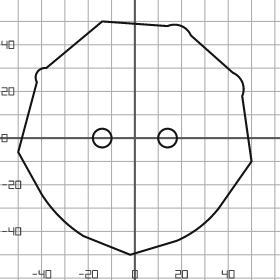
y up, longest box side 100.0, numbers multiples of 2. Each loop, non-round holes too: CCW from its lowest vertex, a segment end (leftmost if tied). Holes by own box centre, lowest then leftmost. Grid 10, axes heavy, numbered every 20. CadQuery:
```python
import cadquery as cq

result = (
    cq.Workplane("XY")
    .moveTo(-2.0, -50.0)
    .lineTo(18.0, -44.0)
    .threePointArc((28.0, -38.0), (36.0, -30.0))
    .lineTo(50.0, -10.0)
    .lineTo(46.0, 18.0)
    .threePointArc((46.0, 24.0), (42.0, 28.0))
    .lineTo(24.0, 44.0)
    .threePointArc((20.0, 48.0), (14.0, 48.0))
    .lineTo(-14.0, 50.0)
    .lineTo(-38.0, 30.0)
    .threePointArc((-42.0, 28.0), (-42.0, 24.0))
    .lineTo(-50.0, -6.0)
    .lineTo(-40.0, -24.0)
    .threePointArc((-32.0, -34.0), (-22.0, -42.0))
    .close()
    .moveTo(-14.0, 0.0)
    .circle(4.0)
    .moveTo(14.0, 0.0)
    .circle(4.0)
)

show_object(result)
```